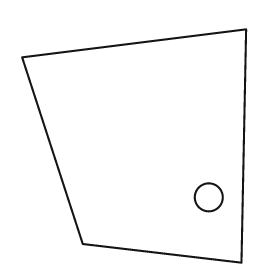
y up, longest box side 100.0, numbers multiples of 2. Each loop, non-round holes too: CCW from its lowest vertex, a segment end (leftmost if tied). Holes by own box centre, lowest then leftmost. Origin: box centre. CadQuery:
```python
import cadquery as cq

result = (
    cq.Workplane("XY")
    .moveTo(46.0, -50.0)
    .lineTo(48.0, 50.0)
    .lineTo(-48.0, 38.0)
    .lineTo(-22.0, -42.0)
    .close()
    .moveTo(32.0, -22.0)
    .circle(6.0)
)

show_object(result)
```